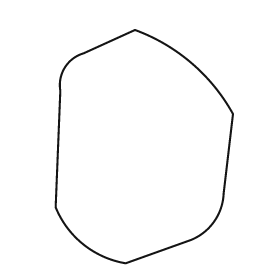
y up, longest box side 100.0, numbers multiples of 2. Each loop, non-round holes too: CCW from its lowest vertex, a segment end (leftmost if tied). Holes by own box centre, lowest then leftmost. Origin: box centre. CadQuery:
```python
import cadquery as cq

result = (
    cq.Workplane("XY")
    .moveTo(-8.0, -50.0)
    .lineTo(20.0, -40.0)
    .threePointArc((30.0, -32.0), (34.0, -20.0))
    .lineTo(38.0, 14.0)
    .threePointArc((20.0, 36.0), (-4.0, 50.0))
    .lineTo(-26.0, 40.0)
    .threePointArc((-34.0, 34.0), (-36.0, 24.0))
    .lineTo(-38.0, -26.0)
    .threePointArc((-26.0, -42.0), (-8.0, -50.0))
    .close()
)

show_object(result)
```